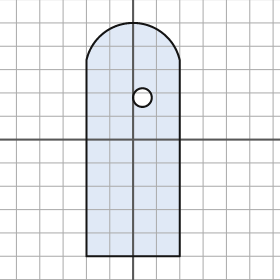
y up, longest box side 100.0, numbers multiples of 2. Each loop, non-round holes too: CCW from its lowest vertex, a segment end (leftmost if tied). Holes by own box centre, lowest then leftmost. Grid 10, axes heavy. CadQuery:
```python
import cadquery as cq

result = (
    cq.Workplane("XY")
    .moveTo(-20.0, -50.0)
    .lineTo(20.0, -50.0)
    .lineTo(20.0, 34.0)
    .threePointArc((0.0, 50.0), (-20.0, 34.0))
    .close()
    .moveTo(4.0, 18.0)
    .circle(4.0)
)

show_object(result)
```